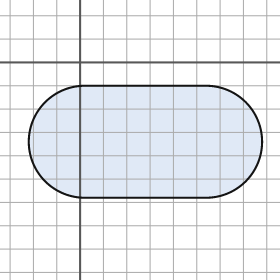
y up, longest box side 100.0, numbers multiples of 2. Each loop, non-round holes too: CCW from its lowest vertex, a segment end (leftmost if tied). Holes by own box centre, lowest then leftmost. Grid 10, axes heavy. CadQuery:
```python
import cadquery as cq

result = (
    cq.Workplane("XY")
    .moveTo(2.0, -58.0)
    .lineTo(54.0, -58.0)
    .threePointArc((78.0, -34.0), (54.0, -10.0))
    .lineTo(2.0, -10.0)
    .threePointArc((-22.0, -34.0), (2.0, -58.0))
    .close()
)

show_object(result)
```